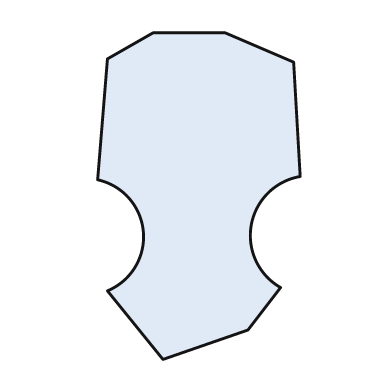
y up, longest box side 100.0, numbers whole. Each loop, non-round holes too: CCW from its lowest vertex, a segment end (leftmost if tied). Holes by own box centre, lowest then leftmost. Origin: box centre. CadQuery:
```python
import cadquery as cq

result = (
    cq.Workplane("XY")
    .moveTo(-11.0, -50.0)
    .lineTo(15.0, -41.0)
    .lineTo(25.0, -28.0)
    .threePointArc((16.0, -9.0), (31.0, 6.0))
    .lineTo(29.0, 41.0)
    .lineTo(8.0, 50.0)
    .lineTo(-14.0, 50.0)
    .lineTo(-28.0, 42.0)
    .lineTo(-31.0, 5.0)
    .threePointArc((-17.0, -11.0), (-28.0, -29.0))
    .close()
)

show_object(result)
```